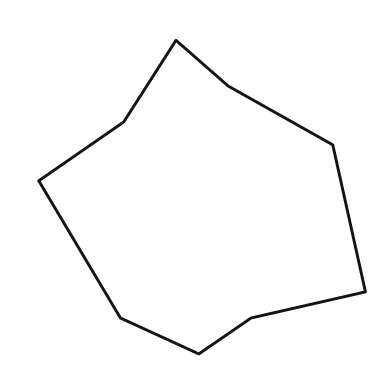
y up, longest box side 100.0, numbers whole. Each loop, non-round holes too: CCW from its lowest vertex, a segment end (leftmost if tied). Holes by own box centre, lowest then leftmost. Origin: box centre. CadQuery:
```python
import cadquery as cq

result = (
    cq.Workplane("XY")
    .moveTo(-1.0, -48.0)
    .lineTo(15.0, -37.0)
    .lineTo(50.0, -29.0)
    .lineTo(40.0, 16.0)
    .lineTo(8.0, 34.0)
    .lineTo(-8.0, 48.0)
    .lineTo(-24.0, 23.0)
    .lineTo(-50.0, 5.0)
    .lineTo(-25.0, -37.0)
    .close()
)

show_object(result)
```